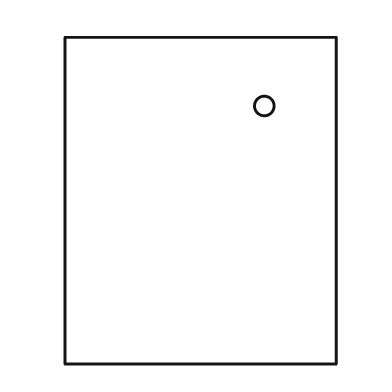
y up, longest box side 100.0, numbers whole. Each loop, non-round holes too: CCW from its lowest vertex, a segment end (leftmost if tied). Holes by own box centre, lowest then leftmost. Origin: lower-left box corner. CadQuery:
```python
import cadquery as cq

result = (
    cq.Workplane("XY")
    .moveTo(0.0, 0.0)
    .lineTo(83.0, 0.0)
    .lineTo(83.0, 100.0)
    .lineTo(0.0, 100.0)
    .close()
    .moveTo(61.0, 79.0)
    .circle(3.0)
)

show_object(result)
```